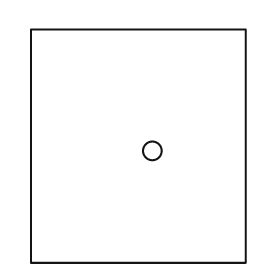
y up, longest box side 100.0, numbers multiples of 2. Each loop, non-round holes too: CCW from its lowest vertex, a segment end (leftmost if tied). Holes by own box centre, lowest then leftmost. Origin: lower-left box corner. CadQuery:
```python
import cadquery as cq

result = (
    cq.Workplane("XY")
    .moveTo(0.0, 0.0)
    .lineTo(92.0, 0.0)
    .lineTo(92.0, 100.0)
    .lineTo(0.0, 100.0)
    .close()
    .moveTo(52.0, 48.0)
    .circle(4.0)
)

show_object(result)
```